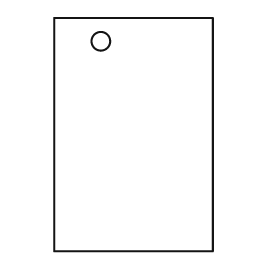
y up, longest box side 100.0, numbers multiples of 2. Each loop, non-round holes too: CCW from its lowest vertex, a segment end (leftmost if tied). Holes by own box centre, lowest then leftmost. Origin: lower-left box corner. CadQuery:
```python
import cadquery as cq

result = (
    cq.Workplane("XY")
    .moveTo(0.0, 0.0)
    .lineTo(68.0, 0.0)
    .lineTo(68.0, 100.0)
    .lineTo(0.0, 100.0)
    .close()
    .moveTo(20.0, 90.0)
    .circle(4.0)
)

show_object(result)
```